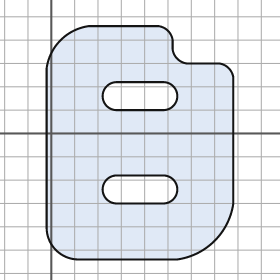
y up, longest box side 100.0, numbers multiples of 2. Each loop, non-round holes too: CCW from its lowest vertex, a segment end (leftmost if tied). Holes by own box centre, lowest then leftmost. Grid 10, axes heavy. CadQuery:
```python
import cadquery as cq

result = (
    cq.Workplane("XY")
    .moveTo(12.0, -54.0)
    .lineTo(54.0, -54.0)
    .threePointArc((70.0, -46.0), (78.0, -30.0))
    .lineTo(78.0, 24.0)
    .threePointArc((76.0, 28.0), (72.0, 30.0))
    .lineTo(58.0, 30.0)
    .threePointArc((54.0, 32.0), (52.0, 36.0))
    .lineTo(52.0, 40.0)
    .threePointArc((50.0, 44.0), (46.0, 46.0))
    .lineTo(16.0, 46.0)
    .threePointArc((4.0, 40.0), (-2.0, 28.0))
    .lineTo(-2.0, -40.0)
    .threePointArc((2.0, -50.0), (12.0, -54.0))
    .close()
    .moveTo(28.0, -30.0)
    .lineTo(48.0, -30.0)
    .threePointArc((54.0, -24.0), (48.0, -18.0))
    .lineTo(28.0, -18.0)
    .threePointArc((22.0, -24.0), (28.0, -30.0))
    .close()
    .moveTo(28.0, 10.0)
    .lineTo(48.0, 10.0)
    .threePointArc((54.0, 16.0), (48.0, 22.0))
    .lineTo(28.0, 22.0)
    .threePointArc((22.0, 16.0), (28.0, 10.0))
    .close()
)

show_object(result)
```